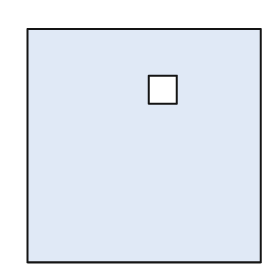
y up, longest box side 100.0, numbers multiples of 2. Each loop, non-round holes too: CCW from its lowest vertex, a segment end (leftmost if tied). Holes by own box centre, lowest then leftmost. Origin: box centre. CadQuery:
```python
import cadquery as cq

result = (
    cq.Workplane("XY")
    .moveTo(-50.0, -50.0)
    .lineTo(50.0, -50.0)
    .lineTo(50.0, 50.0)
    .lineTo(-50.0, 50.0)
    .close()
    .moveTo(2.0, 18.0)
    .lineTo(14.0, 18.0)
    .lineTo(14.0, 30.0)
    .lineTo(2.0, 30.0)
    .close()
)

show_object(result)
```